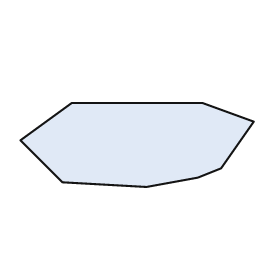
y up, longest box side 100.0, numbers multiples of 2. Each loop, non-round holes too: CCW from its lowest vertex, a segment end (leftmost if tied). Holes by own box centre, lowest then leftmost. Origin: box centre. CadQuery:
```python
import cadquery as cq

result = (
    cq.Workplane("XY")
    .moveTo(4.0, -18.0)
    .lineTo(26.0, -14.0)
    .lineTo(36.0, -10.0)
    .lineTo(50.0, 10.0)
    .lineTo(28.0, 18.0)
    .lineTo(-28.0, 18.0)
    .lineTo(-50.0, 2.0)
    .lineTo(-32.0, -16.0)
    .close()
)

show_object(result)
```